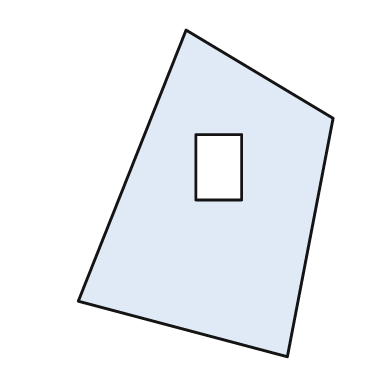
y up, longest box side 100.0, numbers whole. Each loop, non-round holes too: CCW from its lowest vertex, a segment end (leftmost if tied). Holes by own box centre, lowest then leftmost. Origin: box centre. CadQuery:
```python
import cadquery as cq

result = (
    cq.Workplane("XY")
    .moveTo(25.0, -50.0)
    .lineTo(39.0, 23.0)
    .lineTo(-6.0, 50.0)
    .lineTo(-39.0, -33.0)
    .close()
    .moveTo(-3.0, -2.0)
    .lineTo(11.0, -2.0)
    .lineTo(11.0, 18.0)
    .lineTo(-3.0, 18.0)
    .close()
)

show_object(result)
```